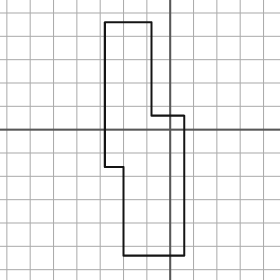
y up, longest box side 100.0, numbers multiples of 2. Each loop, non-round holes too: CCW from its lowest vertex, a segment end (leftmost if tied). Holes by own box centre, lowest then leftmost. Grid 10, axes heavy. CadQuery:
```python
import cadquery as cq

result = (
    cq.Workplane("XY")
    .moveTo(-20.0, -54.0)
    .lineTo(6.0, -54.0)
    .lineTo(6.0, 6.0)
    .lineTo(-8.0, 6.0)
    .lineTo(-8.0, 46.0)
    .lineTo(-28.0, 46.0)
    .lineTo(-28.0, -16.0)
    .lineTo(-20.0, -16.0)
    .close()
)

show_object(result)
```